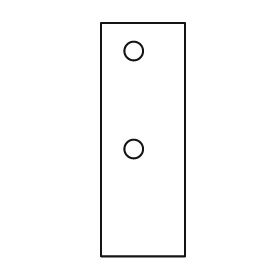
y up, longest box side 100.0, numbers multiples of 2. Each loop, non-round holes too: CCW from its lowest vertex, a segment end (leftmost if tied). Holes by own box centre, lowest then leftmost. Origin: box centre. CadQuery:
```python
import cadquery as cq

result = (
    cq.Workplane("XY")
    .moveTo(-18.0, -50.0)
    .lineTo(18.0, -50.0)
    .lineTo(18.0, 50.0)
    .lineTo(-18.0, 50.0)
    .close()
    .moveTo(-4.0, -4.0)
    .circle(4.0)
    .moveTo(-4.0, 38.0)
    .circle(4.0)
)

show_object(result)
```